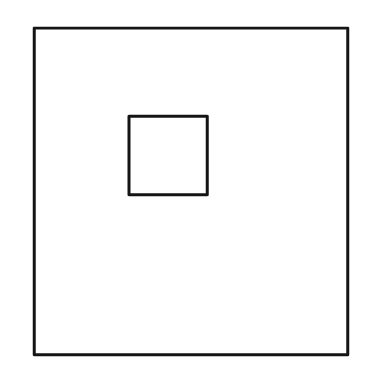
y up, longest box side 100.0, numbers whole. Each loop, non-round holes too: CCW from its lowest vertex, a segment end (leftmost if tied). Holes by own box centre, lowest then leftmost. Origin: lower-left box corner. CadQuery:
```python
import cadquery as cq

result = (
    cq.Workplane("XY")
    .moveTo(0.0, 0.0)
    .lineTo(96.0, 0.0)
    .lineTo(96.0, 100.0)
    .lineTo(0.0, 100.0)
    .close()
    .moveTo(29.0, 49.0)
    .lineTo(53.0, 49.0)
    .lineTo(53.0, 73.0)
    .lineTo(29.0, 73.0)
    .close()
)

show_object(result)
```